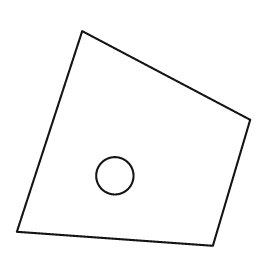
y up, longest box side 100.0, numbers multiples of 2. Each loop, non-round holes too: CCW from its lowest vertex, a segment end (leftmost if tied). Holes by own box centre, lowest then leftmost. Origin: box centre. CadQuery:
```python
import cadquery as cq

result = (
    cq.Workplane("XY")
    .moveTo(34.0, -46.0)
    .lineTo(50.0, 8.0)
    .lineTo(-22.0, 46.0)
    .lineTo(-50.0, -40.0)
    .close()
    .moveTo(-8.0, -16.0)
    .circle(8.0)
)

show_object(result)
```